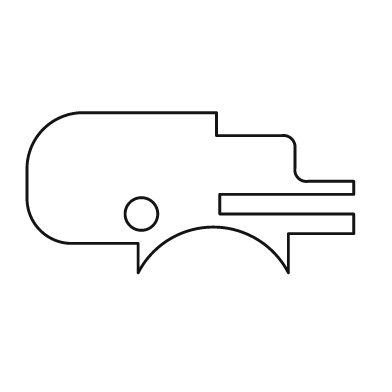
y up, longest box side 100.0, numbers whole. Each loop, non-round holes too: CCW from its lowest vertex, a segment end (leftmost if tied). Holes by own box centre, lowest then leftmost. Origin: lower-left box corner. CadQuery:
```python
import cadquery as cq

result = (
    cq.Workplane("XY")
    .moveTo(34.0, 0.0)
    .threePointArc((57.0, 14.0), (80.0, 0.0))
    .lineTo(80.0, 12.0)
    .lineTo(100.0, 12.0)
    .lineTo(100.0, 18.0)
    .lineTo(59.0, 18.0)
    .lineTo(59.0, 24.0)
    .lineTo(100.0, 24.0)
    .lineTo(100.0, 28.0)
    .lineTo(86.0, 28.0)
    .threePointArc((83.0, 29.0), (82.0, 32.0))
    .lineTo(82.0, 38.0)
    .threePointArc((81.0, 41.0), (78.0, 42.0))
    .lineTo(58.0, 42.0)
    .lineTo(58.0, 49.0)
    .lineTo(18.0, 49.0)
    .threePointArc((5.0, 44.0), (0.0, 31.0))
    .lineTo(0.0, 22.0)
    .threePointArc((4.0, 13.0), (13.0, 9.0))
    .lineTo(34.0, 9.0)
    .close()
    .moveTo(35.0, 18.0)
    .circle(5.0)
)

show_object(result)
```